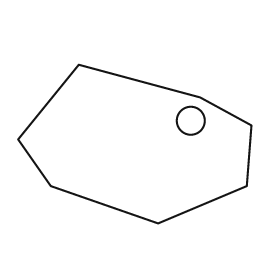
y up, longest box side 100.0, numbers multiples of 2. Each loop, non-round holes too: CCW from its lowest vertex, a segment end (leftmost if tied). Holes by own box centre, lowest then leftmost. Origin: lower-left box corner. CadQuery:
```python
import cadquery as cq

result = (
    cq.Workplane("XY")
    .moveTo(60.0, 0.0)
    .lineTo(98.0, 16.0)
    .lineTo(100.0, 42.0)
    .lineTo(78.0, 54.0)
    .lineTo(26.0, 68.0)
    .lineTo(0.0, 36.0)
    .lineTo(14.0, 16.0)
    .close()
    .moveTo(74.0, 44.0)
    .circle(6.0)
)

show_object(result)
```